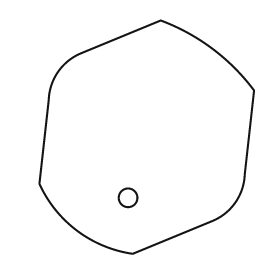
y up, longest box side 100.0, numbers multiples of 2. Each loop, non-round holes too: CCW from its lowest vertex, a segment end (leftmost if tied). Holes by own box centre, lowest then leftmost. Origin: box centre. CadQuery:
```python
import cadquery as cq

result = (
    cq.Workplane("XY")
    .moveTo(-6.0, -50.0)
    .lineTo(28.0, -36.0)
    .threePointArc((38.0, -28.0), (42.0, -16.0))
    .lineTo(46.0, 20.0)
    .threePointArc((28.0, 38.0), (6.0, 50.0))
    .lineTo(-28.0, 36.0)
    .threePointArc((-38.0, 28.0), (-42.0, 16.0))
    .lineTo(-46.0, -20.0)
    .threePointArc((-30.0, -40.0), (-6.0, -50.0))
    .close()
    .moveTo(-8.0, -26.0)
    .circle(4.0)
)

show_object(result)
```